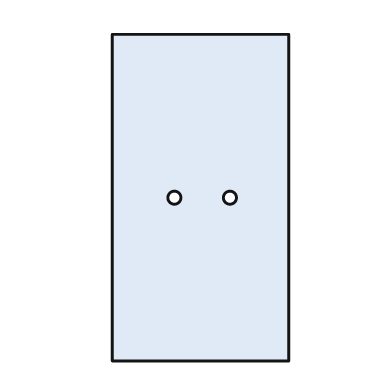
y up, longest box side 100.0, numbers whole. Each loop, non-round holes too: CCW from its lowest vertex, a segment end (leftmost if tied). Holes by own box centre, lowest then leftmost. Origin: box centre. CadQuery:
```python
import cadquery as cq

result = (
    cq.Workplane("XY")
    .moveTo(-27.0, -50.0)
    .lineTo(27.0, -50.0)
    .lineTo(27.0, 50.0)
    .lineTo(-27.0, 50.0)
    .close()
    .moveTo(-8.0, 0.0)
    .circle(2.0)
    .moveTo(9.0, 0.0)
    .circle(2.0)
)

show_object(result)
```